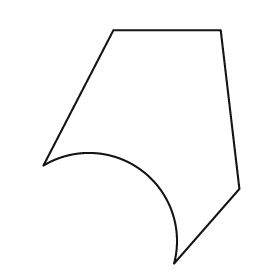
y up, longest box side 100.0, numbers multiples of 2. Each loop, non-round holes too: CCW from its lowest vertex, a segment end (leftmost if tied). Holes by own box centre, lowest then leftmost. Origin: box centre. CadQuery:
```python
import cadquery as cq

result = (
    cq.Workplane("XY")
    .moveTo(14.0, -50.0)
    .lineTo(42.0, -18.0)
    .lineTo(34.0, 50.0)
    .lineTo(-12.0, 50.0)
    .lineTo(-42.0, -8.0)
    .threePointArc((0.0, -10.0), (14.0, -50.0))
    .close()
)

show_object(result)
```